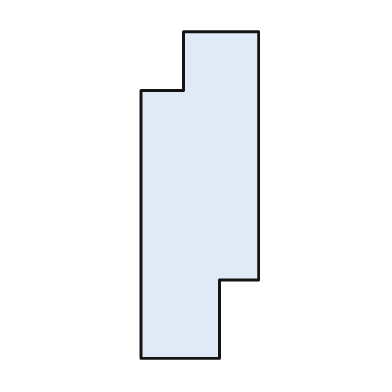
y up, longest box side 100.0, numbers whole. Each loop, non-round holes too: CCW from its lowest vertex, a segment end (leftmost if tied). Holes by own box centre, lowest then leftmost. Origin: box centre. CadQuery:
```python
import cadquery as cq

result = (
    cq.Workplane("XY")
    .moveTo(-18.0, -50.0)
    .lineTo(6.0, -50.0)
    .lineTo(6.0, -26.0)
    .lineTo(18.0, -26.0)
    .lineTo(18.0, 50.0)
    .lineTo(-5.0, 50.0)
    .lineTo(-5.0, 32.0)
    .lineTo(-18.0, 32.0)
    .close()
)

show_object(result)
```